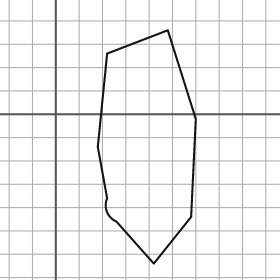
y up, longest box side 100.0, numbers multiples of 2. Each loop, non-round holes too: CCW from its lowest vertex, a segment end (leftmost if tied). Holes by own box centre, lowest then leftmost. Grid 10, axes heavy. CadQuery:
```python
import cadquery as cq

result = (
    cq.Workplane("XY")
    .moveTo(42.0, -64.0)
    .lineTo(58.0, -44.0)
    .lineTo(60.0, -2.0)
    .lineTo(48.0, 36.0)
    .lineTo(22.0, 26.0)
    .lineTo(18.0, -14.0)
    .lineTo(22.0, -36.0)
    .threePointArc((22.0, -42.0), (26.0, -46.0))
    .close()
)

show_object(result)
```